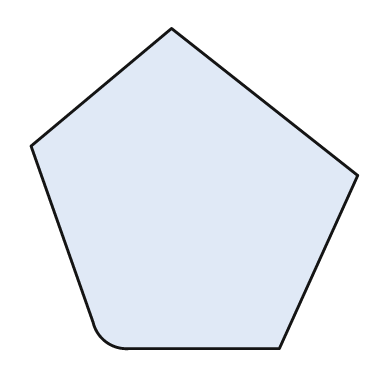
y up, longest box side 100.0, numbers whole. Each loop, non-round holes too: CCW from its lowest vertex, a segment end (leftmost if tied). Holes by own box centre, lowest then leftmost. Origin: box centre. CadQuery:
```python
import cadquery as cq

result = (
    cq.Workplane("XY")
    .moveTo(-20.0, -49.0)
    .lineTo(26.0, -49.0)
    .lineTo(50.0, 4.0)
    .lineTo(-7.0, 49.0)
    .lineTo(-50.0, 13.0)
    .lineTo(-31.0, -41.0)
    .threePointArc((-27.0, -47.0), (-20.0, -49.0))
    .close()
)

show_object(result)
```